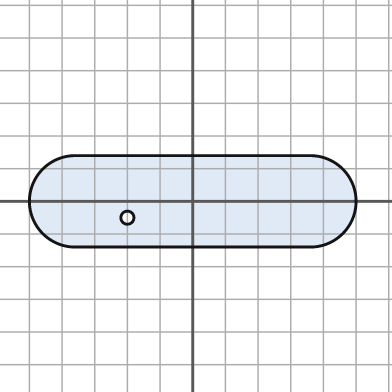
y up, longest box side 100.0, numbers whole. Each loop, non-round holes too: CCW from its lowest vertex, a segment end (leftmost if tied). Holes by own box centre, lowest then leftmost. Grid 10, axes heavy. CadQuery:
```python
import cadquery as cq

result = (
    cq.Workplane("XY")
    .moveTo(-36.0, -14.0)
    .lineTo(36.0, -14.0)
    .threePointArc((50.0, 0.0), (36.0, 14.0))
    .lineTo(-36.0, 14.0)
    .threePointArc((-50.0, 0.0), (-36.0, -14.0))
    .close()
    .moveTo(-20.0, -5.0)
    .circle(2.0)
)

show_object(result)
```